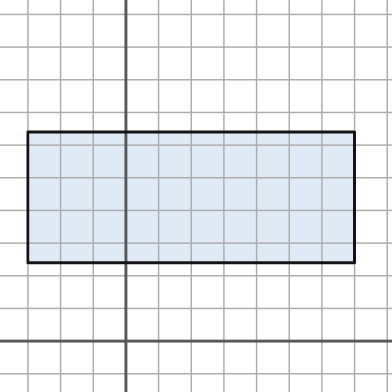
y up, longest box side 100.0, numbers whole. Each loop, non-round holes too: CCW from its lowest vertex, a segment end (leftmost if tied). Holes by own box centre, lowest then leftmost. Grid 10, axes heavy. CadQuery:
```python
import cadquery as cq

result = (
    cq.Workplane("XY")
    .moveTo(-30.0, 24.0)
    .lineTo(70.0, 24.0)
    .lineTo(70.0, 64.0)
    .lineTo(-30.0, 64.0)
    .close()
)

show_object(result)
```